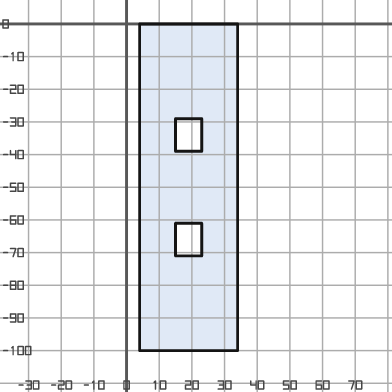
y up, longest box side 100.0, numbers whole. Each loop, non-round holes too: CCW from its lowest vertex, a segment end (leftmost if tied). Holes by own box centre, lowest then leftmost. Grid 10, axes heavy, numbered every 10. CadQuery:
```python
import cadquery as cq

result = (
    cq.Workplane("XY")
    .moveTo(4.0, -100.0)
    .lineTo(34.0, -100.0)
    .lineTo(34.0, 0.0)
    .lineTo(4.0, 0.0)
    .close()
    .moveTo(15.0, -71.0)
    .lineTo(23.0, -71.0)
    .lineTo(23.0, -61.0)
    .lineTo(15.0, -61.0)
    .close()
    .moveTo(15.0, -39.0)
    .lineTo(23.0, -39.0)
    .lineTo(23.0, -29.0)
    .lineTo(15.0, -29.0)
    .close()
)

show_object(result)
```